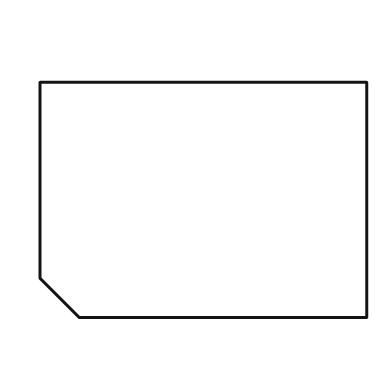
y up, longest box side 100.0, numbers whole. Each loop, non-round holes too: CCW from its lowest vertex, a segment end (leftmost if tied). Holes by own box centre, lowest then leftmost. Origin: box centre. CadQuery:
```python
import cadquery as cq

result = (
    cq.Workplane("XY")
    .moveTo(-38.0, -36.0)
    .lineTo(50.0, -36.0)
    .lineTo(50.0, 36.0)
    .lineTo(-50.0, 36.0)
    .lineTo(-50.0, -24.0)
    .close()
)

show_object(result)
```